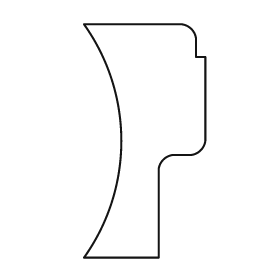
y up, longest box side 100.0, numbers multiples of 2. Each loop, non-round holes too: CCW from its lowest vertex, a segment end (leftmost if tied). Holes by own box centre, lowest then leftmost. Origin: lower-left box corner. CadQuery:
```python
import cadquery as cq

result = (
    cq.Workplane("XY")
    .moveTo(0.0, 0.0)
    .lineTo(32.0, 0.0)
    .lineTo(32.0, 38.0)
    .threePointArc((34.0, 42.0), (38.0, 44.0))
    .lineTo(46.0, 44.0)
    .threePointArc((50.0, 46.0), (52.0, 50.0))
    .lineTo(52.0, 86.0)
    .lineTo(48.0, 86.0)
    .lineTo(48.0, 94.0)
    .threePointArc((46.0, 98.0), (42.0, 100.0))
    .lineTo(0.0, 100.0)
    .threePointArc((16.0, 50.0), (0.0, 0.0))
    .close()
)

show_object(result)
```